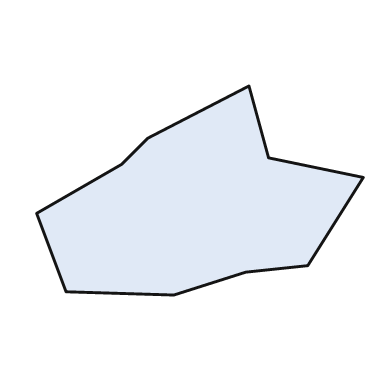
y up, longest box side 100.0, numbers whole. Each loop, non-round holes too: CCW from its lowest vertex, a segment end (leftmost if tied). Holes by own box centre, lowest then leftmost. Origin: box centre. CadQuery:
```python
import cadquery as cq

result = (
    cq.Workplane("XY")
    .moveTo(-8.0, -32.0)
    .lineTo(14.0, -25.0)
    .lineTo(33.0, -23.0)
    .lineTo(50.0, 4.0)
    .lineTo(21.0, 10.0)
    .lineTo(15.0, 32.0)
    .lineTo(-16.0, 16.0)
    .lineTo(-24.0, 8.0)
    .lineTo(-50.0, -7.0)
    .lineTo(-41.0, -31.0)
    .close()
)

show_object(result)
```